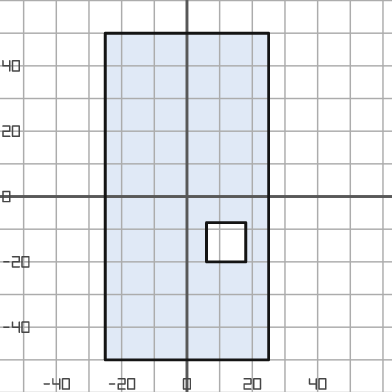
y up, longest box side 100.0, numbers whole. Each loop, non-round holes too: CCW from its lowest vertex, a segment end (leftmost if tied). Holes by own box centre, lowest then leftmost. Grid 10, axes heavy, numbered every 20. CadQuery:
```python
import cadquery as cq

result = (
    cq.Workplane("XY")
    .moveTo(-25.0, -50.0)
    .lineTo(25.0, -50.0)
    .lineTo(25.0, 50.0)
    .lineTo(-25.0, 50.0)
    .close()
    .moveTo(6.0, -20.0)
    .lineTo(18.0, -20.0)
    .lineTo(18.0, -8.0)
    .lineTo(6.0, -8.0)
    .close()
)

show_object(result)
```